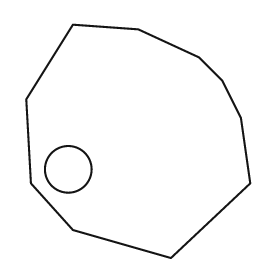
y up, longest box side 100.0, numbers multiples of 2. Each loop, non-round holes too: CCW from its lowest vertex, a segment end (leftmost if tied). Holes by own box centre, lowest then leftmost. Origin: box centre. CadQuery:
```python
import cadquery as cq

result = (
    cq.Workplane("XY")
    .moveTo(14.0, -50.0)
    .lineTo(48.0, -18.0)
    .lineTo(44.0, 10.0)
    .lineTo(36.0, 26.0)
    .lineTo(26.0, 36.0)
    .lineTo(0.0, 48.0)
    .lineTo(-28.0, 50.0)
    .lineTo(-48.0, 18.0)
    .lineTo(-46.0, -18.0)
    .lineTo(-28.0, -38.0)
    .close()
    .moveTo(-30.0, -12.0)
    .circle(10.0)
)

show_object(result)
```